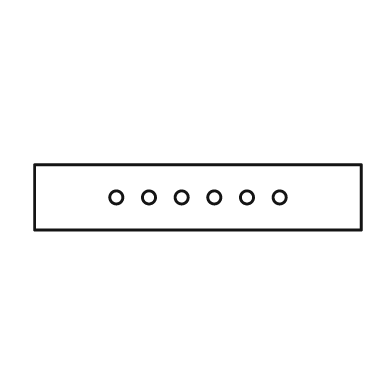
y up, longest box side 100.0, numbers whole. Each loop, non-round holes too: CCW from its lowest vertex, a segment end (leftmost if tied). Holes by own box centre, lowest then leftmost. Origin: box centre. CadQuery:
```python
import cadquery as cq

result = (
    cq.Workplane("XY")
    .moveTo(-50.0, -10.0)
    .lineTo(50.0, -10.0)
    .lineTo(50.0, 10.0)
    .lineTo(-50.0, 10.0)
    .close()
    .moveTo(-25.0, 0.0)
    .circle(2.0)
    .moveTo(-15.0, 0.0)
    .circle(2.0)
    .moveTo(-5.0, 0.0)
    .circle(2.0)
    .moveTo(5.0, 0.0)
    .circle(2.0)
    .moveTo(15.0, 0.0)
    .circle(2.0)
    .moveTo(25.0, 0.0)
    .circle(2.0)
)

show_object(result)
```